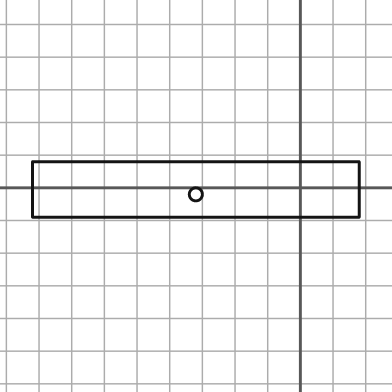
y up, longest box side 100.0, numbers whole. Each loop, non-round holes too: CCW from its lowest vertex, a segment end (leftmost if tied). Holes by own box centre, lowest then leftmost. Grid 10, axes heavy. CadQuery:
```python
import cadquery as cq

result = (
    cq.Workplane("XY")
    .moveTo(-82.0, -9.0)
    .lineTo(18.0, -9.0)
    .lineTo(18.0, 8.0)
    .lineTo(-82.0, 8.0)
    .close()
    .moveTo(-32.0, -2.0)
    .circle(2.0)
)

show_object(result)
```